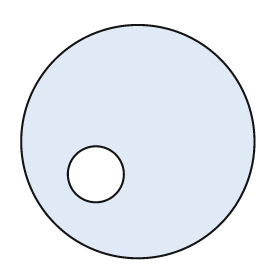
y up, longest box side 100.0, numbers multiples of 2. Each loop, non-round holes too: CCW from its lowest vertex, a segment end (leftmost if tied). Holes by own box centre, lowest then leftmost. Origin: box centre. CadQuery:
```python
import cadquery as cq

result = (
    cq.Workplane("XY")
    .moveTo(0.0, 0.0)
    .circle(50.0)
    .moveTo(-18.0, -14.0)
    .circle(12.0)
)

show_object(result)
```